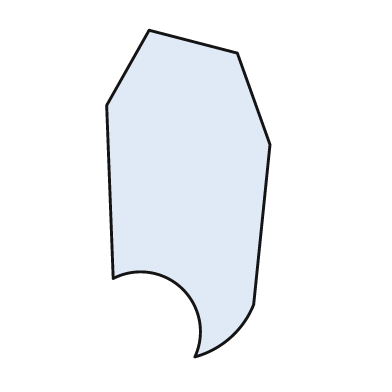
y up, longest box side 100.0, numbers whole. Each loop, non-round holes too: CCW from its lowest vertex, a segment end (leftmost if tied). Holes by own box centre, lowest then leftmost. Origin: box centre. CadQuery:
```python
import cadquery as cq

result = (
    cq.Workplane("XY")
    .moveTo(2.0, -50.0)
    .threePointArc((13.0, -44.0), (20.0, -34.0))
    .lineTo(25.0, 15.0)
    .lineTo(15.0, 43.0)
    .lineTo(-12.0, 50.0)
    .lineTo(-25.0, 27.0)
    .lineTo(-23.0, -26.0)
    .threePointArc((-2.0, -29.0), (2.0, -50.0))
    .close()
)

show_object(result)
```